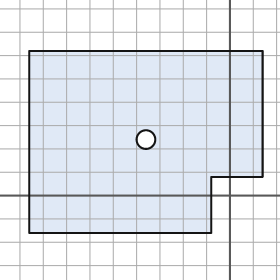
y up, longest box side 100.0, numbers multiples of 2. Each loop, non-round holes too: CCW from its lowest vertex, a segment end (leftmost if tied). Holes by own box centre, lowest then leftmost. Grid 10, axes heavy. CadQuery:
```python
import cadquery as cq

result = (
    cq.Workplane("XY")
    .moveTo(-86.0, -16.0)
    .lineTo(-8.0, -16.0)
    .lineTo(-8.0, 8.0)
    .lineTo(14.0, 8.0)
    .lineTo(14.0, 62.0)
    .lineTo(-86.0, 62.0)
    .close()
    .moveTo(-36.0, 24.0)
    .circle(4.0)
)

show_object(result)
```